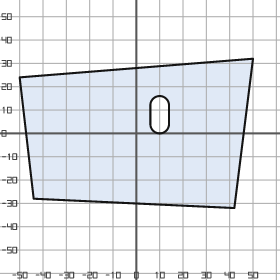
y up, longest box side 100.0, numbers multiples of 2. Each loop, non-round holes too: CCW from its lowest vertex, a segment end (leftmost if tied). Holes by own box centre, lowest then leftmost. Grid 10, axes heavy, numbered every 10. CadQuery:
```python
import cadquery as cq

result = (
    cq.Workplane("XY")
    .moveTo(42.0, -32.0)
    .lineTo(50.0, 32.0)
    .lineTo(-50.0, 24.0)
    .lineTo(-44.0, -28.0)
    .close()
    .moveTo(6.0, 4.0)
    .threePointArc((10.0, 0.0), (14.0, 4.0))
    .lineTo(14.0, 12.0)
    .threePointArc((10.0, 16.0), (6.0, 12.0))
    .close()
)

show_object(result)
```